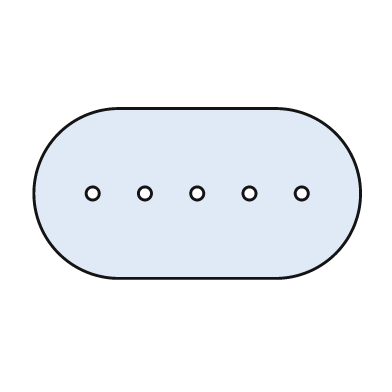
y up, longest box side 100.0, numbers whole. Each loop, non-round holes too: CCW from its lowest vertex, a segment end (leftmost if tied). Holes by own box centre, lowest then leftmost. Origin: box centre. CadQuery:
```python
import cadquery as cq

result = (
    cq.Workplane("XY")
    .moveTo(-24.0, -26.0)
    .lineTo(24.0, -26.0)
    .threePointArc((50.0, 0.0), (24.0, 26.0))
    .lineTo(-24.0, 26.0)
    .threePointArc((-50.0, 0.0), (-24.0, -26.0))
    .close()
    .moveTo(-32.0, 0.0)
    .circle(2.0)
    .moveTo(-16.0, 0.0)
    .circle(2.0)
    .moveTo(0.0, 0.0)
    .circle(2.0)
    .moveTo(16.0, 0.0)
    .circle(2.0)
    .moveTo(32.0, 0.0)
    .circle(2.0)
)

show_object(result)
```